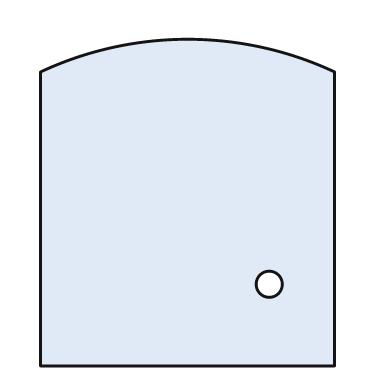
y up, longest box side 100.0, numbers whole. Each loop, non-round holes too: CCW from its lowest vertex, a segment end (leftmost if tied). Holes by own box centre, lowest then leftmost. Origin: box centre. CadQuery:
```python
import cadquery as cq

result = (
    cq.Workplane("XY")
    .moveTo(-45.0, -50.0)
    .lineTo(45.0, -50.0)
    .lineTo(45.0, 40.0)
    .threePointArc((0.0, 50.0), (-45.0, 40.0))
    .close()
    .moveTo(25.0, -25.0)
    .circle(4.0)
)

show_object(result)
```